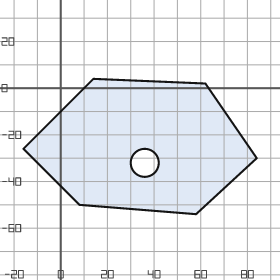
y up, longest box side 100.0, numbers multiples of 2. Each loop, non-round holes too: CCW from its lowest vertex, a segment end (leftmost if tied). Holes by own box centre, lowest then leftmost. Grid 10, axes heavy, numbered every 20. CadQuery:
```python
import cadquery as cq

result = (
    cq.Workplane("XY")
    .moveTo(58.0, -54.0)
    .lineTo(84.0, -30.0)
    .lineTo(62.0, 2.0)
    .lineTo(14.0, 4.0)
    .lineTo(-16.0, -26.0)
    .lineTo(8.0, -50.0)
    .close()
    .moveTo(36.0, -32.0)
    .circle(6.0)
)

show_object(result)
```